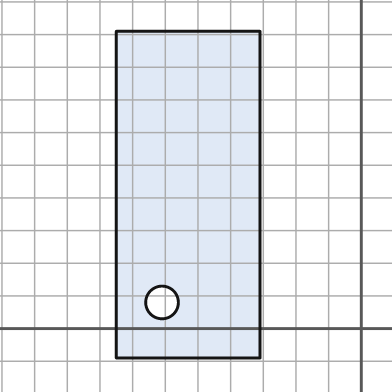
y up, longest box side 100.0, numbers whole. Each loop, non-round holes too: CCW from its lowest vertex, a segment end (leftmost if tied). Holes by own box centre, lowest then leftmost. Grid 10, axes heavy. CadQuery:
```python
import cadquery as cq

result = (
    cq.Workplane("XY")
    .moveTo(-75.0, -9.0)
    .lineTo(-31.0, -9.0)
    .lineTo(-31.0, 91.0)
    .lineTo(-75.0, 91.0)
    .close()
    .moveTo(-61.0, 8.0)
    .circle(5.0)
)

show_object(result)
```